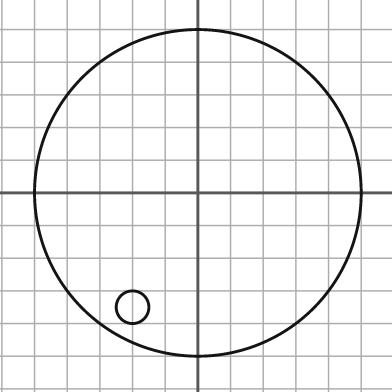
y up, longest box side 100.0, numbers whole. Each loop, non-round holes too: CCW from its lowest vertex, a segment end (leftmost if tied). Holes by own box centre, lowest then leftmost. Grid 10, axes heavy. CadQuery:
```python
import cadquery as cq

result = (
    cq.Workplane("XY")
    .moveTo(0.0, 0.0)
    .circle(50.0)
    .moveTo(-20.0, -35.0)
    .circle(5.0)
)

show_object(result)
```